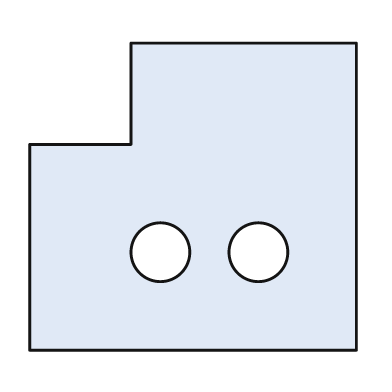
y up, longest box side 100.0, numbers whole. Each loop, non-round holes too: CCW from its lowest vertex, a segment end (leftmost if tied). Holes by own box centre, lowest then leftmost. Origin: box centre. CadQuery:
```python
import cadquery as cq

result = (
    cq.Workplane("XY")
    .moveTo(-50.0, -47.0)
    .lineTo(50.0, -47.0)
    .lineTo(50.0, 47.0)
    .lineTo(-19.0, 47.0)
    .lineTo(-19.0, 16.0)
    .lineTo(-50.0, 16.0)
    .close()
    .moveTo(-10.0, -17.0)
    .circle(9.0)
    .moveTo(20.0, -17.0)
    .circle(9.0)
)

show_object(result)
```